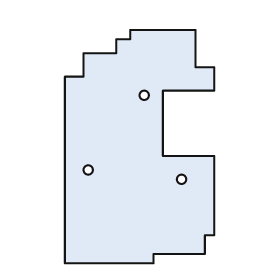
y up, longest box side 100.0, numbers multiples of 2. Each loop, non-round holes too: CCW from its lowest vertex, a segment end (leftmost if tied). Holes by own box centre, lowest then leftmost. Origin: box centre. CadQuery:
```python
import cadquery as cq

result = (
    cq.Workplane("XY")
    .moveTo(-32.0, -50.0)
    .lineTo(6.0, -50.0)
    .lineTo(6.0, -46.0)
    .lineTo(28.0, -46.0)
    .lineTo(28.0, -38.0)
    .lineTo(32.0, -38.0)
    .lineTo(32.0, -4.0)
    .lineTo(10.0, -4.0)
    .lineTo(10.0, 24.0)
    .lineTo(32.0, 24.0)
    .lineTo(32.0, 34.0)
    .lineTo(24.0, 34.0)
    .lineTo(24.0, 50.0)
    .lineTo(-4.0, 50.0)
    .lineTo(-4.0, 46.0)
    .lineTo(-10.0, 46.0)
    .lineTo(-10.0, 40.0)
    .lineTo(-24.0, 40.0)
    .lineTo(-24.0, 30.0)
    .lineTo(-32.0, 30.0)
    .close()
    .moveTo(18.0, -14.0)
    .circle(2.0)
    .moveTo(-22.0, -10.0)
    .circle(2.0)
    .moveTo(2.0, 22.0)
    .circle(2.0)
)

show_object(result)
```